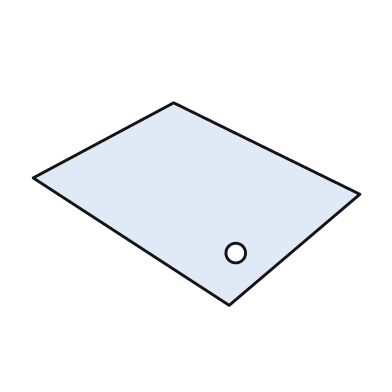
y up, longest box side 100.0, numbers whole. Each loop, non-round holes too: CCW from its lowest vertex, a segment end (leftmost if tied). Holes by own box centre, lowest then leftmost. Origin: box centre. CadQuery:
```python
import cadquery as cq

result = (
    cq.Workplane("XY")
    .moveTo(10.0, -31.0)
    .lineTo(50.0, 3.0)
    .lineTo(-7.0, 31.0)
    .lineTo(-50.0, 8.0)
    .close()
    .moveTo(12.0, -15.0)
    .circle(3.0)
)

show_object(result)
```